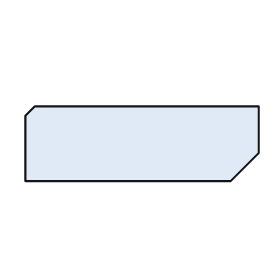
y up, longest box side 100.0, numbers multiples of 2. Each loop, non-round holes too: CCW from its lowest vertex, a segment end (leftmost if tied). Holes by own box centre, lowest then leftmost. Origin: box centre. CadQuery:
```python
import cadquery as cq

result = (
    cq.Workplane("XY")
    .moveTo(-50.0, -16.0)
    .lineTo(38.0, -16.0)
    .lineTo(50.0, -4.0)
    .lineTo(50.0, 16.0)
    .lineTo(-46.0, 16.0)
    .lineTo(-50.0, 12.0)
    .close()
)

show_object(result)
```